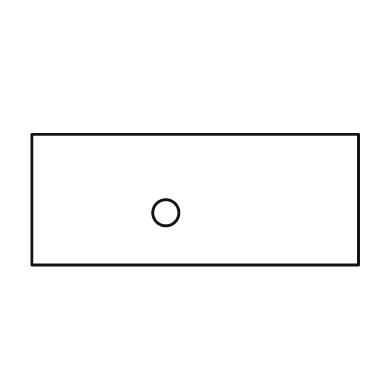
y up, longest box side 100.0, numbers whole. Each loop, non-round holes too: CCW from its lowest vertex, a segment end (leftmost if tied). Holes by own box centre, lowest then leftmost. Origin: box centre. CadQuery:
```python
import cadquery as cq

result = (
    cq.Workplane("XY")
    .moveTo(-50.0, -20.0)
    .lineTo(50.0, -20.0)
    .lineTo(50.0, 20.0)
    .lineTo(-50.0, 20.0)
    .close()
    .moveTo(-9.0, -4.0)
    .circle(4.0)
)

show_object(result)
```